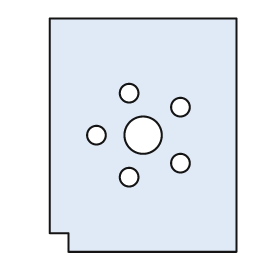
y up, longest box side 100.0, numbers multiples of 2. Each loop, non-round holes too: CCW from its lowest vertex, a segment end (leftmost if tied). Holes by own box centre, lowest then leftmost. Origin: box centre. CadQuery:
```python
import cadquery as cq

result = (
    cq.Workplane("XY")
    .moveTo(-32.0, -50.0)
    .lineTo(40.0, -50.0)
    .lineTo(40.0, 50.0)
    .lineTo(-40.0, 50.0)
    .lineTo(-40.0, -42.0)
    .lineTo(-32.0, -42.0)
    .close()
    .moveTo(-6.0, -18.0)
    .circle(4.0)
    .moveTo(16.0, -12.0)
    .circle(4.0)
    .moveTo(-20.0, 0.0)
    .circle(4.0)
    .moveTo(0.0, 0.0)
    .circle(8.0)
    .moveTo(16.0, 12.0)
    .circle(4.0)
    .moveTo(-6.0, 18.0)
    .circle(4.0)
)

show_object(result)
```